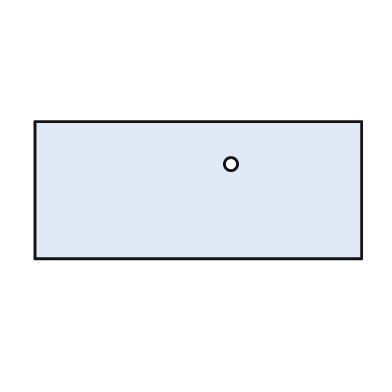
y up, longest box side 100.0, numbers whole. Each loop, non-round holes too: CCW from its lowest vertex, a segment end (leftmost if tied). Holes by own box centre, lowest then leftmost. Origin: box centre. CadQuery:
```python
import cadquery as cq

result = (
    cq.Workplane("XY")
    .moveTo(-50.0, -21.0)
    .lineTo(50.0, -21.0)
    .lineTo(50.0, 21.0)
    .lineTo(-50.0, 21.0)
    .close()
    .moveTo(10.0, 8.0)
    .circle(2.0)
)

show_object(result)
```